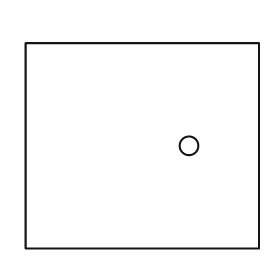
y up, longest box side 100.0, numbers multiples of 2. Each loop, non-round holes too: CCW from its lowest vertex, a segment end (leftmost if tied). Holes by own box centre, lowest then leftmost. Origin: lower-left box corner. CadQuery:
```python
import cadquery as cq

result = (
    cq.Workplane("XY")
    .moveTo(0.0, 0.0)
    .lineTo(100.0, 0.0)
    .lineTo(100.0, 88.0)
    .lineTo(0.0, 88.0)
    .close()
    .moveTo(70.0, 44.0)
    .circle(4.0)
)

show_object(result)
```